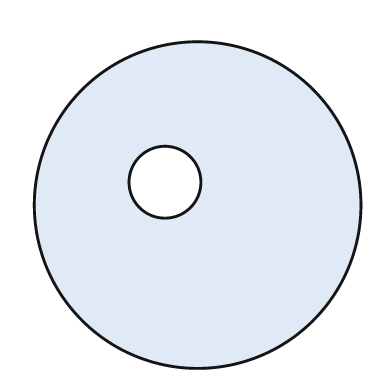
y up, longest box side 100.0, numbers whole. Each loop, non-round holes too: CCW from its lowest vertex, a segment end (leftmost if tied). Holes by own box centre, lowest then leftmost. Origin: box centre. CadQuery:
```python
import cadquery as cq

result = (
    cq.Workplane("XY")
    .moveTo(0.0, 0.0)
    .circle(50.0)
    .moveTo(-10.0, 7.0)
    .circle(11.0)
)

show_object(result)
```